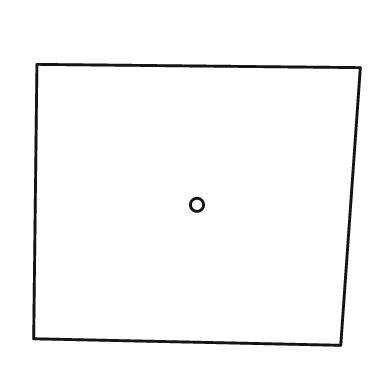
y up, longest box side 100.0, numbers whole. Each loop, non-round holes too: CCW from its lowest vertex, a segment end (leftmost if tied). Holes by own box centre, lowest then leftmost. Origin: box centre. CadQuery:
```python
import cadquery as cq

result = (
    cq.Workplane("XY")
    .moveTo(44.0, -43.0)
    .lineTo(50.0, 42.0)
    .lineTo(-49.0, 43.0)
    .lineTo(-50.0, -41.0)
    .close()
    .moveTo(0.0, 0.0)
    .circle(2.0)
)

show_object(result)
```